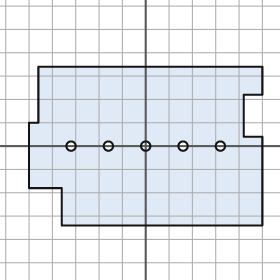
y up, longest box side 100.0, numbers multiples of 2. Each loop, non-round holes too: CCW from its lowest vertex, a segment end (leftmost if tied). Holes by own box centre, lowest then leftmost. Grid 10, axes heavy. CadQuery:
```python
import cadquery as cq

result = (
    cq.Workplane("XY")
    .moveTo(-36.0, -34.0)
    .lineTo(50.0, -34.0)
    .lineTo(50.0, 4.0)
    .lineTo(42.0, 4.0)
    .lineTo(42.0, 22.0)
    .lineTo(50.0, 22.0)
    .lineTo(50.0, 34.0)
    .lineTo(-46.0, 34.0)
    .lineTo(-46.0, 10.0)
    .lineTo(-50.0, 10.0)
    .lineTo(-50.0, -18.0)
    .lineTo(-36.0, -18.0)
    .close()
    .moveTo(-32.0, 0.0)
    .circle(2.0)
    .moveTo(-16.0, 0.0)
    .circle(2.0)
    .moveTo(0.0, 0.0)
    .circle(2.0)
    .moveTo(16.0, 0.0)
    .circle(2.0)
    .moveTo(32.0, 0.0)
    .circle(2.0)
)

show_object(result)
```